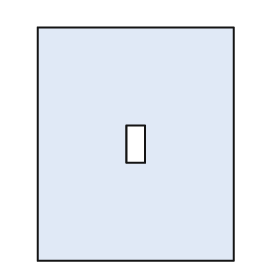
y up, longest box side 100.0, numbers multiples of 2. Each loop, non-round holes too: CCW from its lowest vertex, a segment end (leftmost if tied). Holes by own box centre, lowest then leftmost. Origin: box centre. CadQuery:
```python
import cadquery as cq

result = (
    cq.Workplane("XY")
    .moveTo(-42.0, -50.0)
    .lineTo(42.0, -50.0)
    .lineTo(42.0, 50.0)
    .lineTo(-42.0, 50.0)
    .close()
    .moveTo(-4.0, -8.0)
    .lineTo(4.0, -8.0)
    .lineTo(4.0, 8.0)
    .lineTo(-4.0, 8.0)
    .close()
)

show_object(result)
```